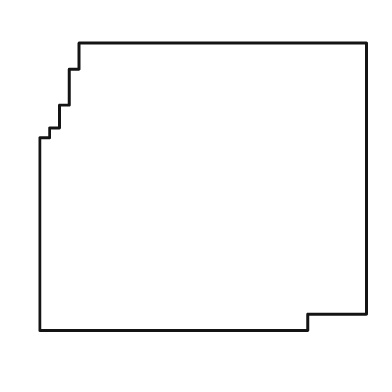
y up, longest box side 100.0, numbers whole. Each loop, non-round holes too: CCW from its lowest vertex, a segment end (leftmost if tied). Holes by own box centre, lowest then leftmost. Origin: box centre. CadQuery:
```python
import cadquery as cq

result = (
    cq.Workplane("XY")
    .moveTo(-50.0, -44.0)
    .lineTo(32.0, -44.0)
    .lineTo(32.0, -39.0)
    .lineTo(50.0, -39.0)
    .lineTo(50.0, 44.0)
    .lineTo(-38.0, 44.0)
    .lineTo(-38.0, 36.0)
    .lineTo(-41.0, 36.0)
    .lineTo(-41.0, 25.0)
    .lineTo(-44.0, 25.0)
    .lineTo(-44.0, 18.0)
    .lineTo(-47.0, 18.0)
    .lineTo(-47.0, 15.0)
    .lineTo(-50.0, 15.0)
    .close()
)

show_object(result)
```